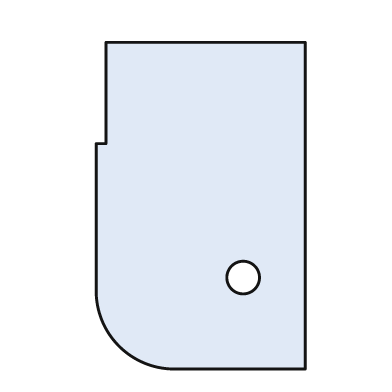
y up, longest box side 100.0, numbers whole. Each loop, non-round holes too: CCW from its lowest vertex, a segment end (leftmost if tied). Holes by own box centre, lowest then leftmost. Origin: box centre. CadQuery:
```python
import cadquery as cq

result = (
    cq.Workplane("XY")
    .moveTo(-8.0, -50.0)
    .lineTo(32.0, -50.0)
    .lineTo(32.0, 50.0)
    .lineTo(-29.0, 50.0)
    .lineTo(-29.0, 19.0)
    .lineTo(-32.0, 19.0)
    .lineTo(-32.0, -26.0)
    .threePointArc((-25.0, -43.0), (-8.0, -50.0))
    .close()
    .moveTo(13.0, -22.0)
    .circle(5.0)
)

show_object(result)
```